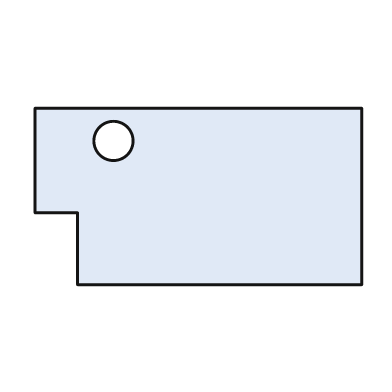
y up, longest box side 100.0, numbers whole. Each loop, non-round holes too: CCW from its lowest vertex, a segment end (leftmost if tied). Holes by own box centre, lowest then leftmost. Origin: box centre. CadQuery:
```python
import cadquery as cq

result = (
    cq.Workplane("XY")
    .moveTo(-37.0, -27.0)
    .lineTo(50.0, -27.0)
    .lineTo(50.0, 27.0)
    .lineTo(-50.0, 27.0)
    .lineTo(-50.0, -5.0)
    .lineTo(-37.0, -5.0)
    .close()
    .moveTo(-26.0, 17.0)
    .circle(6.0)
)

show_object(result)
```